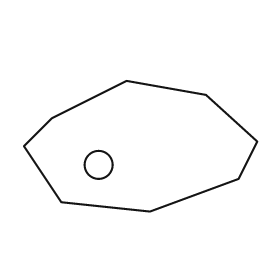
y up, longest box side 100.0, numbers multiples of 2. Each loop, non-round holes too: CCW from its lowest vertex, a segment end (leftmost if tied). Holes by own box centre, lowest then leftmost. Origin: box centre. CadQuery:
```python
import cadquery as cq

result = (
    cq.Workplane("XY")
    .moveTo(4.0, -28.0)
    .lineTo(42.0, -14.0)
    .lineTo(50.0, 2.0)
    .lineTo(28.0, 22.0)
    .lineTo(-6.0, 28.0)
    .lineTo(-38.0, 12.0)
    .lineTo(-50.0, 0.0)
    .lineTo(-34.0, -24.0)
    .close()
    .moveTo(-18.0, -8.0)
    .circle(6.0)
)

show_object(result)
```